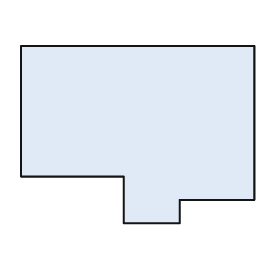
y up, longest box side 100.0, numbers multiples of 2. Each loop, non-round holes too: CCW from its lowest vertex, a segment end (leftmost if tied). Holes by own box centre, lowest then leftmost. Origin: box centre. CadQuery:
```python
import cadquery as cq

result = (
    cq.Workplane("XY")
    .moveTo(-6.0, -38.0)
    .lineTo(18.0, -38.0)
    .lineTo(18.0, -28.0)
    .lineTo(50.0, -28.0)
    .lineTo(50.0, 38.0)
    .lineTo(-50.0, 38.0)
    .lineTo(-50.0, -18.0)
    .lineTo(-6.0, -18.0)
    .close()
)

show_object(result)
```